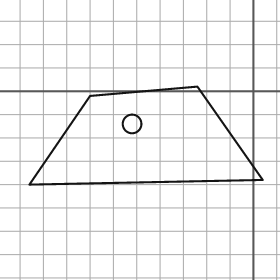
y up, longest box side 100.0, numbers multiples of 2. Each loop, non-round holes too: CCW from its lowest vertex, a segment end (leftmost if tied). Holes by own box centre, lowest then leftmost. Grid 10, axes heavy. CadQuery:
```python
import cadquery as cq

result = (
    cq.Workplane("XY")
    .moveTo(-96.0, -40.0)
    .lineTo(4.0, -38.0)
    .lineTo(-24.0, 2.0)
    .lineTo(-70.0, -2.0)
    .close()
    .moveTo(-52.0, -14.0)
    .circle(4.0)
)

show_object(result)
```